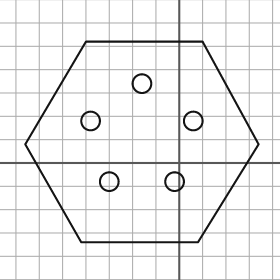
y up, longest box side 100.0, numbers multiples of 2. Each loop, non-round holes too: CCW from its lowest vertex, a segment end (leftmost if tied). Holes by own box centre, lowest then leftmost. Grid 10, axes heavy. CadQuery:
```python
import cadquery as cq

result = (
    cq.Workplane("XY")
    .moveTo(-42.0, -34.0)
    .lineTo(8.0, -34.0)
    .lineTo(34.0, 8.0)
    .lineTo(10.0, 52.0)
    .lineTo(-40.0, 52.0)
    .lineTo(-66.0, 8.0)
    .close()
    .moveTo(-30.0, -8.0)
    .circle(4.0)
    .moveTo(-2.0, -8.0)
    .circle(4.0)
    .moveTo(-38.0, 18.0)
    .circle(4.0)
    .moveTo(6.0, 18.0)
    .circle(4.0)
    .moveTo(-16.0, 34.0)
    .circle(4.0)
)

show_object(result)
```